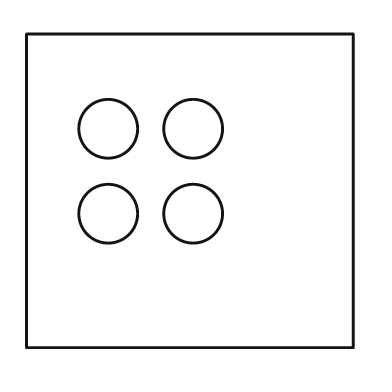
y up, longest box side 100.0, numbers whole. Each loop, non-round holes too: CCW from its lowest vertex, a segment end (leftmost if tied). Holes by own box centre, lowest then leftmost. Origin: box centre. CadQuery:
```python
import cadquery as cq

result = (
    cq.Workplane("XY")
    .moveTo(-50.0, -48.0)
    .lineTo(50.0, -48.0)
    .lineTo(50.0, 48.0)
    .lineTo(-50.0, 48.0)
    .close()
    .moveTo(-25.0, -7.0)
    .circle(9.0)
    .moveTo(1.0, -7.0)
    .circle(9.0)
    .moveTo(-25.0, 19.0)
    .circle(9.0)
    .moveTo(1.0, 19.0)
    .circle(9.0)
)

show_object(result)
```